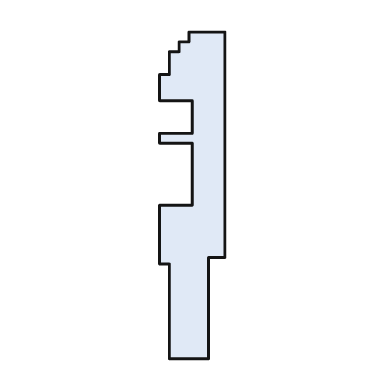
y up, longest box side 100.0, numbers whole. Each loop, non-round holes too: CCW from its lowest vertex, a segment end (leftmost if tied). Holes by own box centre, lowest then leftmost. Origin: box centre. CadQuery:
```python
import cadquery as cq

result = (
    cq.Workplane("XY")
    .moveTo(-7.0, -50.0)
    .lineTo(5.0, -50.0)
    .lineTo(5.0, -19.0)
    .lineTo(10.0, -19.0)
    .lineTo(10.0, 50.0)
    .lineTo(-1.0, 50.0)
    .lineTo(-1.0, 47.0)
    .lineTo(-4.0, 47.0)
    .lineTo(-4.0, 44.0)
    .lineTo(-7.0, 44.0)
    .lineTo(-7.0, 37.0)
    .lineTo(-10.0, 37.0)
    .lineTo(-10.0, 29.0)
    .lineTo(0.0, 29.0)
    .lineTo(0.0, 19.0)
    .lineTo(-10.0, 19.0)
    .lineTo(-10.0, 16.0)
    .lineTo(0.0, 16.0)
    .lineTo(0.0, -3.0)
    .lineTo(-10.0, -3.0)
    .lineTo(-10.0, -21.0)
    .lineTo(-7.0, -21.0)
    .close()
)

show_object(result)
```